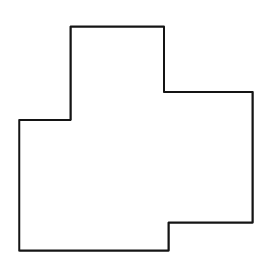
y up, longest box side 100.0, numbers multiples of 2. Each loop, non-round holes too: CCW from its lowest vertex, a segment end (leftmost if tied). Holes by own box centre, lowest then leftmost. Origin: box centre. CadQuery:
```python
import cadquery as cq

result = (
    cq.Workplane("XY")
    .moveTo(-50.0, -48.0)
    .lineTo(14.0, -48.0)
    .lineTo(14.0, -36.0)
    .lineTo(50.0, -36.0)
    .lineTo(50.0, 20.0)
    .lineTo(12.0, 20.0)
    .lineTo(12.0, 48.0)
    .lineTo(-28.0, 48.0)
    .lineTo(-28.0, 8.0)
    .lineTo(-50.0, 8.0)
    .close()
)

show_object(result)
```